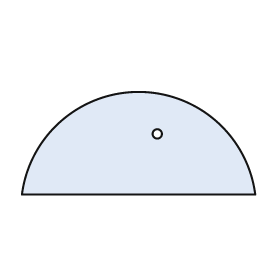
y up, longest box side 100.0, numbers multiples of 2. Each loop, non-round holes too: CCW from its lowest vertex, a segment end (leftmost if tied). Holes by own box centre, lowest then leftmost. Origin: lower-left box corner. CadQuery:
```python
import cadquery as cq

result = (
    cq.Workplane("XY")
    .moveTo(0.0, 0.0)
    .lineTo(100.0, 0.0)
    .threePointArc((50.0, 44.0), (0.0, 0.0))
    .close()
    .moveTo(58.0, 26.0)
    .circle(2.0)
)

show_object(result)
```